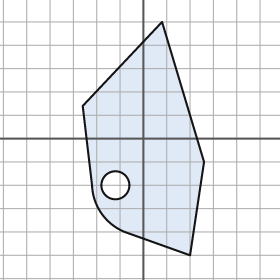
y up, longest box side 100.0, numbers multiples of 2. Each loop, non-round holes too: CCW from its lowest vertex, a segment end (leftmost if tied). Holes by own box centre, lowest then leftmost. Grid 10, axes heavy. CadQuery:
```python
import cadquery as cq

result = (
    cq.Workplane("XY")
    .moveTo(20.0, -50.0)
    .lineTo(26.0, -10.0)
    .lineTo(8.0, 50.0)
    .lineTo(-26.0, 14.0)
    .lineTo(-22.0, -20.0)
    .threePointArc((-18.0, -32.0), (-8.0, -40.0))
    .close()
    .moveTo(-12.0, -20.0)
    .circle(6.0)
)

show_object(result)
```